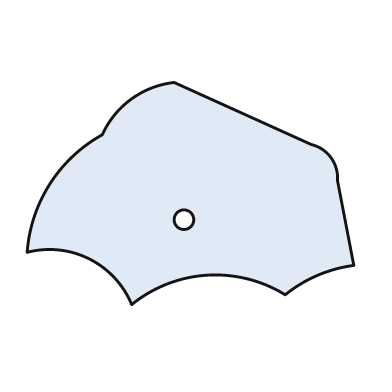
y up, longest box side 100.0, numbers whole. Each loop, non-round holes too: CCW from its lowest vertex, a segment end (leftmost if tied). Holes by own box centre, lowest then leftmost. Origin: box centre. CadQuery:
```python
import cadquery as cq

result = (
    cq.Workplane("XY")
    .moveTo(-18.0, -34.0)
    .threePointArc((5.0, -25.0), (29.0, -31.0))
    .threePointArc((39.0, -25.0), (50.0, -22.0))
    .lineTo(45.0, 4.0)
    .threePointArc((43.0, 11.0), (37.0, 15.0))
    .lineTo(-5.0, 34.0)
    .threePointArc((-18.0, 29.0), (-27.0, 18.0))
    .threePointArc((-43.0, 3.0), (-50.0, -18.0))
    .threePointArc((-31.0, -20.0), (-18.0, -34.0))
    .close()
    .moveTo(-2.0, -8.0)
    .circle(3.0)
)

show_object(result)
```